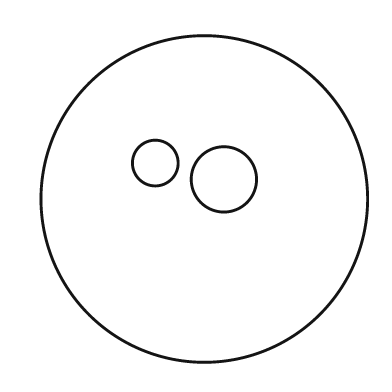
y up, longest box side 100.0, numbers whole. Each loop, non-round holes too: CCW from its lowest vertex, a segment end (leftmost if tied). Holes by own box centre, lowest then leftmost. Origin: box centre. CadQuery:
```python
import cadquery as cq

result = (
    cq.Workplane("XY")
    .moveTo(0.0, 0.0)
    .circle(50.0)
    .moveTo(6.0, 6.0)
    .circle(10.0)
    .moveTo(-15.0, 11.0)
    .circle(7.0)
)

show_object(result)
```